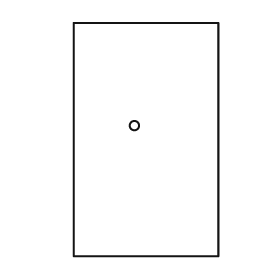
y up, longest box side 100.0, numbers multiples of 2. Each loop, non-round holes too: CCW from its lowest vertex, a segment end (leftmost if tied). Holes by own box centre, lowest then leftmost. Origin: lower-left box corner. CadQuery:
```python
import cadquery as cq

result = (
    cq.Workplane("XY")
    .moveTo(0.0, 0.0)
    .lineTo(62.0, 0.0)
    .lineTo(62.0, 100.0)
    .lineTo(0.0, 100.0)
    .close()
    .moveTo(26.0, 56.0)
    .circle(2.0)
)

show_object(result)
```